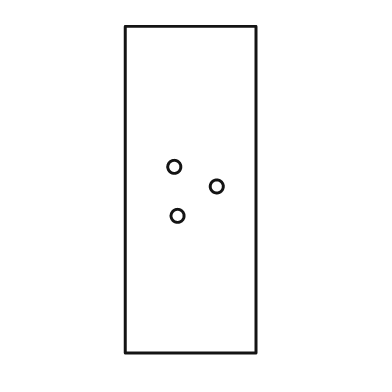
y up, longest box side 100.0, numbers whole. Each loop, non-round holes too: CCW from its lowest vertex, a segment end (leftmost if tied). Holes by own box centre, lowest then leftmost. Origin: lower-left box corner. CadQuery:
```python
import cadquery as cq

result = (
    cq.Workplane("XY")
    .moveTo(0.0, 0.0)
    .lineTo(40.0, 0.0)
    .lineTo(40.0, 100.0)
    .lineTo(0.0, 100.0)
    .close()
    .moveTo(16.0, 42.0)
    .circle(2.0)
    .moveTo(28.0, 51.0)
    .circle(2.0)
    .moveTo(15.0, 57.0)
    .circle(2.0)
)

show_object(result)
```